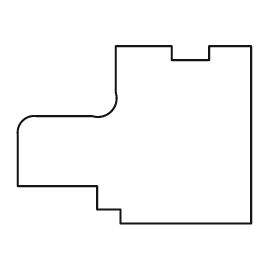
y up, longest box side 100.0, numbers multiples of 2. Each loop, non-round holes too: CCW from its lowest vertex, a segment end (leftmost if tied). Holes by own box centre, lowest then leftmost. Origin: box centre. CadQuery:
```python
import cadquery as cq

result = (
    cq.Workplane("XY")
    .moveTo(-6.0, -38.0)
    .lineTo(50.0, -38.0)
    .lineTo(50.0, 38.0)
    .lineTo(32.0, 38.0)
    .lineTo(32.0, 32.0)
    .lineTo(16.0, 32.0)
    .lineTo(16.0, 38.0)
    .lineTo(-8.0, 38.0)
    .lineTo(-8.0, 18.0)
    .threePointArc((-10.0, 10.0), (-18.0, 8.0))
    .lineTo(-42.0, 8.0)
    .threePointArc((-48.0, 6.0), (-50.0, 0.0))
    .lineTo(-50.0, -22.0)
    .lineTo(-16.0, -22.0)
    .lineTo(-16.0, -32.0)
    .lineTo(-6.0, -32.0)
    .close()
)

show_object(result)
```